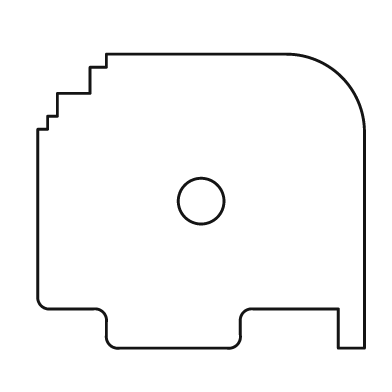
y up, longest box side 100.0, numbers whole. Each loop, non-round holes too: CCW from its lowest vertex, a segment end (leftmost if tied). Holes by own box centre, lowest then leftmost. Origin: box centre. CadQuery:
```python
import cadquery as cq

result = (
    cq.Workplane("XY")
    .moveTo(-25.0, -45.0)
    .lineTo(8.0, -45.0)
    .threePointArc((11.0, -44.0), (12.0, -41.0))
    .lineTo(12.0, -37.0)
    .threePointArc((13.0, -34.0), (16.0, -33.0))
    .lineTo(42.0, -33.0)
    .lineTo(42.0, -45.0)
    .lineTo(50.0, -45.0)
    .lineTo(50.0, 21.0)
    .threePointArc((43.0, 38.0), (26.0, 45.0))
    .lineTo(-29.0, 45.0)
    .lineTo(-29.0, 41.0)
    .lineTo(-34.0, 41.0)
    .lineTo(-34.0, 33.0)
    .lineTo(-44.0, 33.0)
    .lineTo(-44.0, 26.0)
    .lineTo(-47.0, 26.0)
    .lineTo(-47.0, 22.0)
    .lineTo(-50.0, 22.0)
    .lineTo(-50.0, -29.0)
    .threePointArc((-49.0, -32.0), (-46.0, -33.0))
    .lineTo(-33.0, -33.0)
    .threePointArc((-30.0, -34.0), (-29.0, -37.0))
    .lineTo(-29.0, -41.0)
    .threePointArc((-28.0, -44.0), (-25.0, -45.0))
    .close()
    .moveTo(0.0, 0.0)
    .circle(7.0)
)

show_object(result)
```